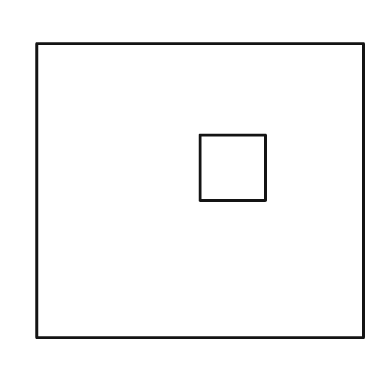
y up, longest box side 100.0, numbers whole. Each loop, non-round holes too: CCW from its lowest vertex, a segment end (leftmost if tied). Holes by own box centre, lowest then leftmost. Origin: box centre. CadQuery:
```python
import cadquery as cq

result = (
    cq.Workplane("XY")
    .moveTo(-50.0, -45.0)
    .lineTo(50.0, -45.0)
    .lineTo(50.0, 45.0)
    .lineTo(-50.0, 45.0)
    .close()
    .moveTo(0.0, -3.0)
    .lineTo(20.0, -3.0)
    .lineTo(20.0, 17.0)
    .lineTo(0.0, 17.0)
    .close()
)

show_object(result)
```